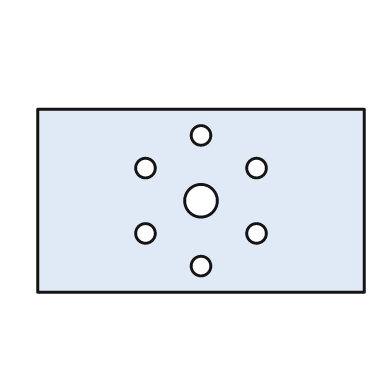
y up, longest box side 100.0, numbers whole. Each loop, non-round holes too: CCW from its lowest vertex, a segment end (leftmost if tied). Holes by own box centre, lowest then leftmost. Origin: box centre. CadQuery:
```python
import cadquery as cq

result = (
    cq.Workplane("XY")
    .moveTo(-50.0, -28.0)
    .lineTo(50.0, -28.0)
    .lineTo(50.0, 28.0)
    .lineTo(-50.0, 28.0)
    .close()
    .moveTo(0.0, -20.0)
    .circle(3.0)
    .moveTo(-17.0, -10.0)
    .circle(3.0)
    .moveTo(17.0, -10.0)
    .circle(3.0)
    .moveTo(0.0, 0.0)
    .circle(5.0)
    .moveTo(-17.0, 10.0)
    .circle(3.0)
    .moveTo(17.0, 10.0)
    .circle(3.0)
    .moveTo(0.0, 20.0)
    .circle(3.0)
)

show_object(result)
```